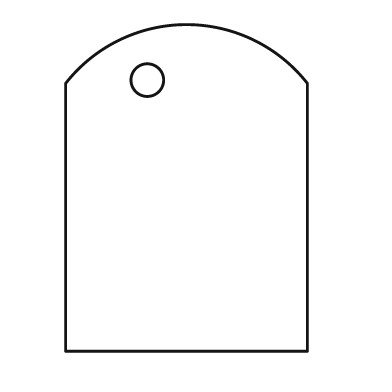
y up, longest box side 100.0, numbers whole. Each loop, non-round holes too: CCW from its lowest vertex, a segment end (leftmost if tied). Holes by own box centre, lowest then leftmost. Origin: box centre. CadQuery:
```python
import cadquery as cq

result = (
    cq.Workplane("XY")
    .moveTo(-37.0, -50.0)
    .lineTo(37.0, -50.0)
    .lineTo(37.0, 32.0)
    .threePointArc((0.0, 50.0), (-37.0, 32.0))
    .close()
    .moveTo(-12.0, 33.0)
    .circle(5.0)
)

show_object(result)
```